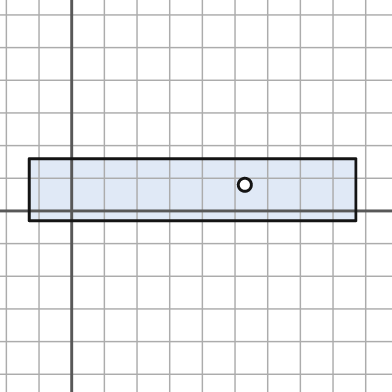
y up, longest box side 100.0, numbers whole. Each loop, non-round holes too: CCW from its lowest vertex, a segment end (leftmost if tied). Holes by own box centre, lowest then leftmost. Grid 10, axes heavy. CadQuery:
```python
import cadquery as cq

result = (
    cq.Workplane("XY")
    .moveTo(-13.0, -3.0)
    .lineTo(87.0, -3.0)
    .lineTo(87.0, 16.0)
    .lineTo(-13.0, 16.0)
    .close()
    .moveTo(53.0, 8.0)
    .circle(2.0)
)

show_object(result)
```